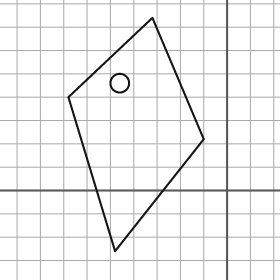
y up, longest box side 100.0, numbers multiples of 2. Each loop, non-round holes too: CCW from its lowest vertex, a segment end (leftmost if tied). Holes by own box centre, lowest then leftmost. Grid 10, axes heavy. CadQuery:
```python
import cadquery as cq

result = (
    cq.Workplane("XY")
    .moveTo(-48.0, -26.0)
    .lineTo(-10.0, 22.0)
    .lineTo(-32.0, 74.0)
    .lineTo(-68.0, 40.0)
    .close()
    .moveTo(-46.0, 46.0)
    .circle(4.0)
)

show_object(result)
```